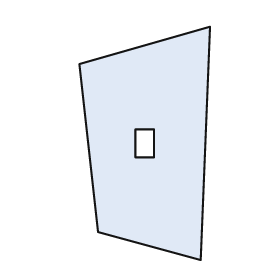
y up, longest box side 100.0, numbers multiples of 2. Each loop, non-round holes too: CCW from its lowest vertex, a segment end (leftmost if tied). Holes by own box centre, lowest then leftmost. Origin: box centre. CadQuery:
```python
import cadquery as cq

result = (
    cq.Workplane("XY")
    .moveTo(24.0, -50.0)
    .lineTo(28.0, 50.0)
    .lineTo(-28.0, 34.0)
    .lineTo(-20.0, -38.0)
    .close()
    .moveTo(-4.0, -6.0)
    .lineTo(4.0, -6.0)
    .lineTo(4.0, 6.0)
    .lineTo(-4.0, 6.0)
    .close()
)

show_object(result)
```